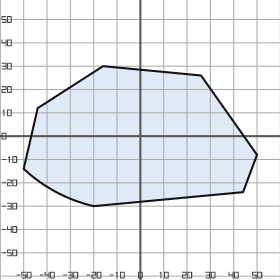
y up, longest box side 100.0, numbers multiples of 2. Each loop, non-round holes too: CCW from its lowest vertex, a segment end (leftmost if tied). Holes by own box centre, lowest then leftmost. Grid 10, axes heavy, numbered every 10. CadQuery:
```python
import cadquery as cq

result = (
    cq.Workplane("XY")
    .moveTo(-20.0, -30.0)
    .lineTo(44.0, -24.0)
    .lineTo(50.0, -8.0)
    .lineTo(26.0, 26.0)
    .lineTo(-16.0, 30.0)
    .lineTo(-44.0, 12.0)
    .lineTo(-50.0, -14.0)
    .threePointArc((-36.0, -24.0), (-20.0, -30.0))
    .close()
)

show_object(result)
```